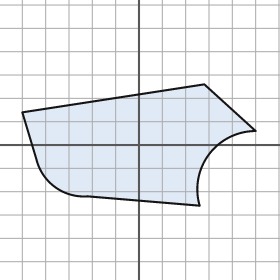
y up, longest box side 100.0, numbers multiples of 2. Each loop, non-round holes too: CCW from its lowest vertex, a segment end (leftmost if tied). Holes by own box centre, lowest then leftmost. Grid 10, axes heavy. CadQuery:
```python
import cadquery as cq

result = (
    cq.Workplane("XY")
    .moveTo(26.0, -26.0)
    .threePointArc((30.0, -4.0), (50.0, 6.0))
    .lineTo(28.0, 26.0)
    .lineTo(-50.0, 14.0)
    .lineTo(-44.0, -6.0)
    .threePointArc((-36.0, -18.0), (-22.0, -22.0))
    .close()
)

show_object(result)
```